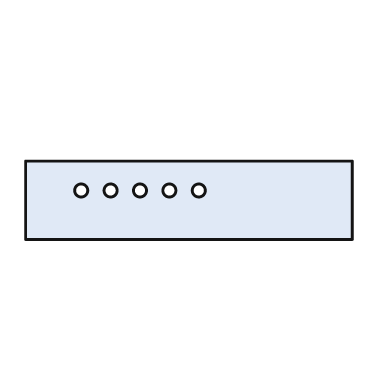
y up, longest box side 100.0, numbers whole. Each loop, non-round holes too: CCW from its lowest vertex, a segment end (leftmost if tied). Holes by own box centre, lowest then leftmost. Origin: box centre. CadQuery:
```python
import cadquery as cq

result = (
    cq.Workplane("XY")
    .moveTo(-50.0, -12.0)
    .lineTo(50.0, -12.0)
    .lineTo(50.0, 12.0)
    .lineTo(-50.0, 12.0)
    .close()
    .moveTo(-33.0, 3.0)
    .circle(2.0)
    .moveTo(-24.0, 3.0)
    .circle(2.0)
    .moveTo(-15.0, 3.0)
    .circle(2.0)
    .moveTo(-6.0, 3.0)
    .circle(2.0)
    .moveTo(3.0, 3.0)
    .circle(2.0)
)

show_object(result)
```